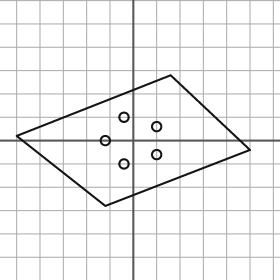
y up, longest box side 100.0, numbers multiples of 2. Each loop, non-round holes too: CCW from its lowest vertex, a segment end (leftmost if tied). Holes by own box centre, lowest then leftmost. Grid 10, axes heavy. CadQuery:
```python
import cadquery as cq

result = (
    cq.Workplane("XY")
    .moveTo(-12.0, -28.0)
    .lineTo(50.0, -4.0)
    .lineTo(16.0, 28.0)
    .lineTo(-50.0, 2.0)
    .close()
    .moveTo(-4.0, -10.0)
    .circle(2.0)
    .moveTo(10.0, -6.0)
    .circle(2.0)
    .moveTo(-12.0, 0.0)
    .circle(2.0)
    .moveTo(10.0, 6.0)
    .circle(2.0)
    .moveTo(-4.0, 10.0)
    .circle(2.0)
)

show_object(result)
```